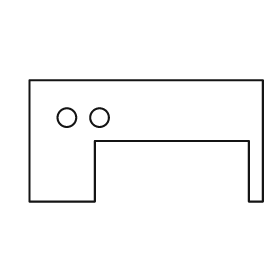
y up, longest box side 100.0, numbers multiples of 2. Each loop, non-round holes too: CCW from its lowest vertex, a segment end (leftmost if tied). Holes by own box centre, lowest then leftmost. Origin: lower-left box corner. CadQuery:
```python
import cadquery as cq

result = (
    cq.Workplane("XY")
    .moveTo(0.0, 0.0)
    .lineTo(28.0, 0.0)
    .lineTo(28.0, 26.0)
    .lineTo(94.0, 26.0)
    .lineTo(94.0, 0.0)
    .lineTo(100.0, 0.0)
    .lineTo(100.0, 52.0)
    .lineTo(0.0, 52.0)
    .close()
    .moveTo(16.0, 36.0)
    .circle(4.0)
    .moveTo(30.0, 36.0)
    .circle(4.0)
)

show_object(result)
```